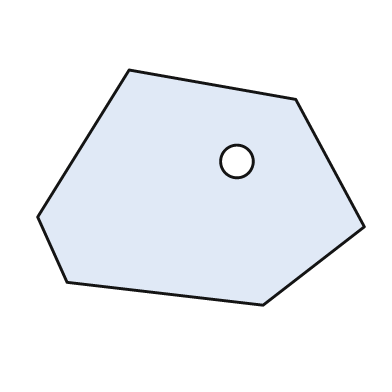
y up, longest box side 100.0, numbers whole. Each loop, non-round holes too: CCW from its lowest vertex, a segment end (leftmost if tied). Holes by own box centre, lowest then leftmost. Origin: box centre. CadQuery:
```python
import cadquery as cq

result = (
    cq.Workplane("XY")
    .moveTo(19.0, -36.0)
    .lineTo(50.0, -12.0)
    .lineTo(29.0, 27.0)
    .lineTo(-22.0, 36.0)
    .lineTo(-50.0, -9.0)
    .lineTo(-41.0, -29.0)
    .close()
    .moveTo(11.0, 8.0)
    .circle(5.0)
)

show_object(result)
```